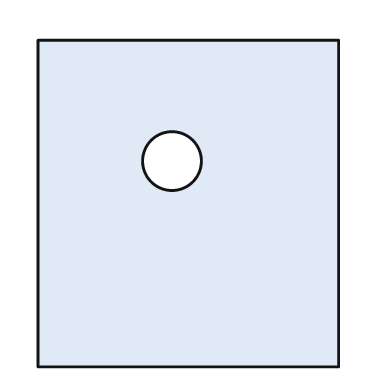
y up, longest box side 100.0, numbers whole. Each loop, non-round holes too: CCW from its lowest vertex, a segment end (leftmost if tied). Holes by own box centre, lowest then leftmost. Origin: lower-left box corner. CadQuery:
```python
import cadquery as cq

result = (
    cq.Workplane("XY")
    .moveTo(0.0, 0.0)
    .lineTo(92.0, 0.0)
    .lineTo(92.0, 100.0)
    .lineTo(0.0, 100.0)
    .close()
    .moveTo(41.0, 63.0)
    .circle(9.0)
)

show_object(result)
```